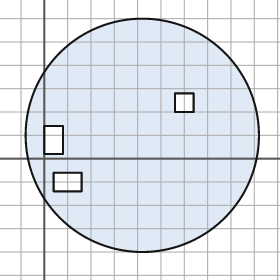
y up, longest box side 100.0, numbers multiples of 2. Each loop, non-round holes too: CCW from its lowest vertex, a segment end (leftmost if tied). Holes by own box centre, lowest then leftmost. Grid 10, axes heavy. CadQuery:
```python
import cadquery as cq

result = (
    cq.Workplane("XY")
    .moveTo(42.0, 10.0)
    .circle(50.0)
    .moveTo(4.0, -14.0)
    .lineTo(16.0, -14.0)
    .lineTo(16.0, -6.0)
    .lineTo(4.0, -6.0)
    .close()
    .moveTo(0.0, 2.0)
    .lineTo(8.0, 2.0)
    .lineTo(8.0, 14.0)
    .lineTo(0.0, 14.0)
    .close()
    .moveTo(56.0, 20.0)
    .lineTo(64.0, 20.0)
    .lineTo(64.0, 28.0)
    .lineTo(56.0, 28.0)
    .close()
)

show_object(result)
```